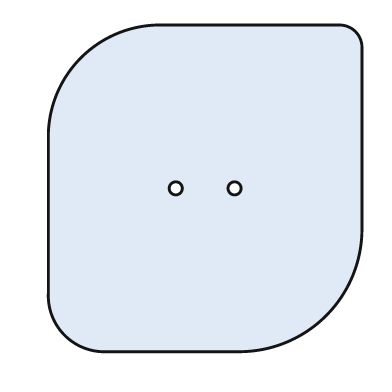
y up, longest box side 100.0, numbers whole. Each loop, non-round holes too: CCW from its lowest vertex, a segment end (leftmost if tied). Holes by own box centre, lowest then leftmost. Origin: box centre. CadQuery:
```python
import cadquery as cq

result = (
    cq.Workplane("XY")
    .moveTo(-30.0, -50.0)
    .lineTo(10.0, -50.0)
    .threePointArc((37.0, -39.0), (48.0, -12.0))
    .lineTo(48.0, 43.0)
    .threePointArc((46.0, 48.0), (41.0, 50.0))
    .lineTo(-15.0, 50.0)
    .threePointArc((-38.0, 40.0), (-48.0, 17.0))
    .lineTo(-48.0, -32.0)
    .threePointArc((-43.0, -45.0), (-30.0, -50.0))
    .close()
    .moveTo(-9.0, 0.0)
    .circle(2.0)
    .moveTo(9.0, 0.0)
    .circle(2.0)
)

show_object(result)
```